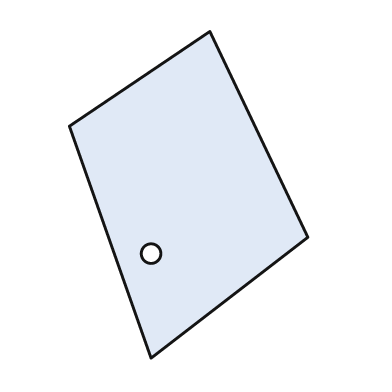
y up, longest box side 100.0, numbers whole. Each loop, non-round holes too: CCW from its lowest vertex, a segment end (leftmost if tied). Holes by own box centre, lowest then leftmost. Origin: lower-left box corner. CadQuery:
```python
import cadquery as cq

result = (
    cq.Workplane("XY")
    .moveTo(25.0, 0.0)
    .lineTo(73.0, 37.0)
    .lineTo(43.0, 100.0)
    .lineTo(0.0, 71.0)
    .close()
    .moveTo(25.0, 32.0)
    .circle(3.0)
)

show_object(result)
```